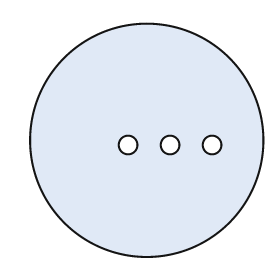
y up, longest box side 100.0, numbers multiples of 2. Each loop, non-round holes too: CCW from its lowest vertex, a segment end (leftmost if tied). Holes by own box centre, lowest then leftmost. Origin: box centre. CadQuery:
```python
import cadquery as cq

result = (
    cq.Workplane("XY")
    .moveTo(0.0, 0.0)
    .circle(50.0)
    .moveTo(-8.0, -2.0)
    .circle(4.0)
    .moveTo(10.0, -2.0)
    .circle(4.0)
    .moveTo(28.0, -2.0)
    .circle(4.0)
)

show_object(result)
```